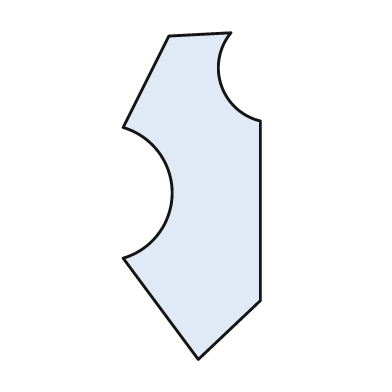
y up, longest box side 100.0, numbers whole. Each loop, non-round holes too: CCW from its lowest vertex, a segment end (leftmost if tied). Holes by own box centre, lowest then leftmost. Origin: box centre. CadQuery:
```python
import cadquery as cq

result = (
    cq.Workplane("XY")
    .moveTo(2.0, -50.0)
    .lineTo(21.0, -32.0)
    .lineTo(21.0, 23.0)
    .threePointArc((9.0, 34.0), (12.0, 50.0))
    .lineTo(-7.0, 49.0)
    .lineTo(-21.0, 21.0)
    .threePointArc((-6.0, 1.0), (-21.0, -19.0))
    .close()
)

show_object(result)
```